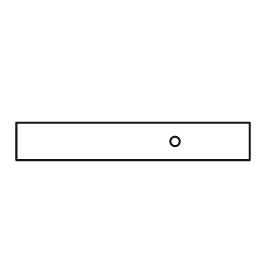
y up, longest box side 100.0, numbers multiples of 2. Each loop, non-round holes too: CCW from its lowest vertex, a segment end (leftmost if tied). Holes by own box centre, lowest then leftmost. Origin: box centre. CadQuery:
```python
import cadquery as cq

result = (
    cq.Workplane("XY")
    .moveTo(-50.0, -8.0)
    .lineTo(50.0, -8.0)
    .lineTo(50.0, 8.0)
    .lineTo(-50.0, 8.0)
    .close()
    .moveTo(18.0, 0.0)
    .circle(2.0)
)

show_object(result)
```